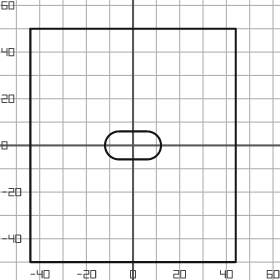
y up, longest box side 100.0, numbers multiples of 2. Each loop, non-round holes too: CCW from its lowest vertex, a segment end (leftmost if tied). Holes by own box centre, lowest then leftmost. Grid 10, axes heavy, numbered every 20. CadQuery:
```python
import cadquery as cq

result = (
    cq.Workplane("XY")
    .moveTo(-44.0, -50.0)
    .lineTo(44.0, -50.0)
    .lineTo(44.0, 50.0)
    .lineTo(-44.0, 50.0)
    .close()
    .moveTo(-6.0, -6.0)
    .lineTo(6.0, -6.0)
    .threePointArc((12.0, 0.0), (6.0, 6.0))
    .lineTo(-6.0, 6.0)
    .threePointArc((-12.0, 0.0), (-6.0, -6.0))
    .close()
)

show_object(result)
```